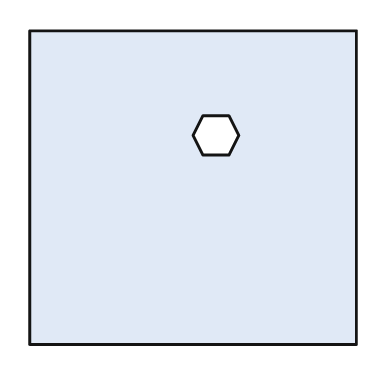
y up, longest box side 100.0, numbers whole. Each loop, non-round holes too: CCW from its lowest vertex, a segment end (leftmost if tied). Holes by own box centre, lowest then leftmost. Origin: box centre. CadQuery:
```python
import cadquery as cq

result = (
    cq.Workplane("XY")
    .moveTo(-50.0, -48.0)
    .lineTo(50.0, -48.0)
    .lineTo(50.0, 48.0)
    .lineTo(-50.0, 48.0)
    .close()
    .moveTo(3.0, 10.0)
    .lineTo(11.0, 10.0)
    .lineTo(14.0, 16.0)
    .lineTo(11.0, 22.0)
    .lineTo(3.0, 22.0)
    .lineTo(0.0, 16.0)
    .close()
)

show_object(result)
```